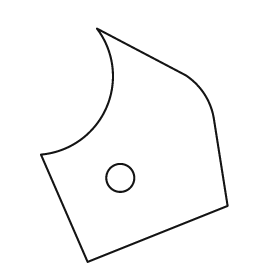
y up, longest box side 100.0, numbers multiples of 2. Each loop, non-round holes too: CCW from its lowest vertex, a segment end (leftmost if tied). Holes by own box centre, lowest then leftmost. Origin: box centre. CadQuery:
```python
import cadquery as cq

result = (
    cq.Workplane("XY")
    .moveTo(-20.0, -50.0)
    .lineTo(40.0, -26.0)
    .lineTo(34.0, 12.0)
    .threePointArc((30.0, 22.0), (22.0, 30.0))
    .lineTo(-16.0, 50.0)
    .threePointArc((-12.0, 16.0), (-40.0, -4.0))
    .close()
    .moveTo(-6.0, -14.0)
    .circle(6.0)
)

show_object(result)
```